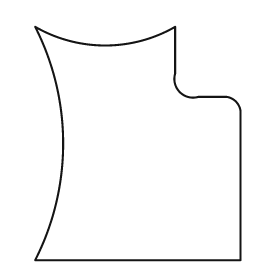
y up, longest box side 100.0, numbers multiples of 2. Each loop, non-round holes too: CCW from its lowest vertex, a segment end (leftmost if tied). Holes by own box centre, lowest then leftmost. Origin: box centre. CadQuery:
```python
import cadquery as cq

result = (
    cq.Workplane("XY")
    .moveTo(-44.0, -50.0)
    .lineTo(44.0, -50.0)
    .lineTo(44.0, 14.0)
    .threePointArc((42.0, 18.0), (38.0, 20.0))
    .lineTo(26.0, 20.0)
    .threePointArc((18.0, 22.0), (16.0, 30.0))
    .lineTo(16.0, 50.0)
    .threePointArc((-14.0, 42.0), (-44.0, 50.0))
    .threePointArc((-32.0, 0.0), (-44.0, -50.0))
    .close()
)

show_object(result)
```